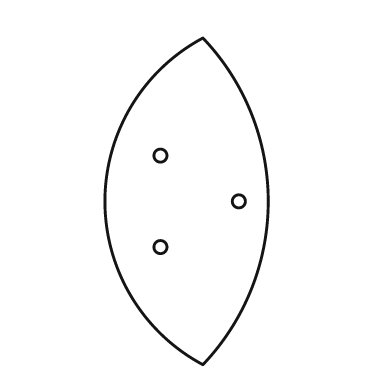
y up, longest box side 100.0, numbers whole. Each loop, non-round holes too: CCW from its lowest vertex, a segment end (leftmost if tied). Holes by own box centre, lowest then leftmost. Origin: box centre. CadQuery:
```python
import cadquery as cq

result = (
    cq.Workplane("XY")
    .moveTo(5.0, -50.0)
    .threePointArc((25.0, 0.0), (5.0, 50.0))
    .threePointArc((-25.0, 0.0), (5.0, -50.0))
    .close()
    .moveTo(-8.0, -14.0)
    .circle(2.0)
    .moveTo(16.0, 0.0)
    .circle(2.0)
    .moveTo(-8.0, 14.0)
    .circle(2.0)
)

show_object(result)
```